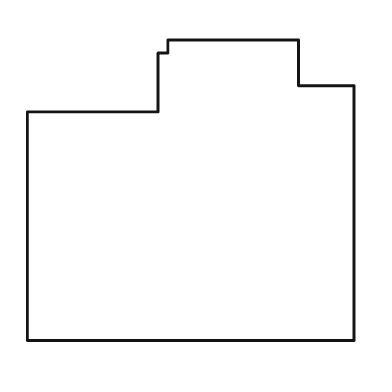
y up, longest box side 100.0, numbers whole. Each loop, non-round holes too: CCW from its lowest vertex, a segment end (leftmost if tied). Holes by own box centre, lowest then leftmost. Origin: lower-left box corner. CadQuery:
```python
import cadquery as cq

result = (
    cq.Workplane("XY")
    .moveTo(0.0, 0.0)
    .lineTo(100.0, 0.0)
    .lineTo(100.0, 78.0)
    .lineTo(83.0, 78.0)
    .lineTo(83.0, 92.0)
    .lineTo(43.0, 92.0)
    .lineTo(43.0, 88.0)
    .lineTo(40.0, 88.0)
    .lineTo(40.0, 70.0)
    .lineTo(0.0, 70.0)
    .close()
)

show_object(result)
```